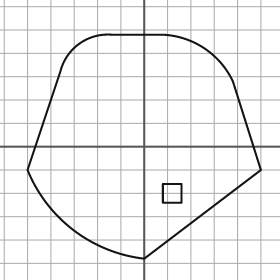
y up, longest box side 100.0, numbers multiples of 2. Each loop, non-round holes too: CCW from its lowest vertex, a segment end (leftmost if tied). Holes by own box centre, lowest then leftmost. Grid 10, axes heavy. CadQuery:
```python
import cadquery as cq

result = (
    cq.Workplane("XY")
    .moveTo(0.0, -48.0)
    .lineTo(50.0, -10.0)
    .lineTo(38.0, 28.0)
    .threePointArc((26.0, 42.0), (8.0, 48.0))
    .lineTo(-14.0, 48.0)
    .threePointArc((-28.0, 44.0), (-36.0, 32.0))
    .lineTo(-50.0, -10.0)
    .threePointArc((-30.0, -36.0), (0.0, -48.0))
    .close()
    .moveTo(8.0, -24.0)
    .lineTo(16.0, -24.0)
    .lineTo(16.0, -16.0)
    .lineTo(8.0, -16.0)
    .close()
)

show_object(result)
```